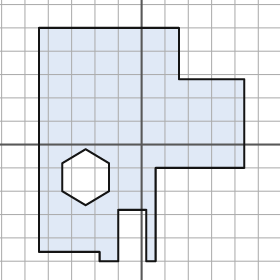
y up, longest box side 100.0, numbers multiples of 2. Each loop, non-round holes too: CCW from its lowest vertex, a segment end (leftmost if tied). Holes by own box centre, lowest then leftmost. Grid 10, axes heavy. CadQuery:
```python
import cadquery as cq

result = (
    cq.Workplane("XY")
    .moveTo(-18.0, -50.0)
    .lineTo(-10.0, -50.0)
    .lineTo(-10.0, -28.0)
    .lineTo(2.0, -28.0)
    .lineTo(2.0, -50.0)
    .lineTo(6.0, -50.0)
    .lineTo(6.0, -10.0)
    .lineTo(44.0, -10.0)
    .lineTo(44.0, 28.0)
    .lineTo(16.0, 28.0)
    .lineTo(16.0, 50.0)
    .lineTo(-44.0, 50.0)
    .lineTo(-44.0, -46.0)
    .lineTo(-18.0, -46.0)
    .close()
    .moveTo(-24.0, -26.0)
    .lineTo(-14.0, -20.0)
    .lineTo(-14.0, -8.0)
    .lineTo(-24.0, -2.0)
    .lineTo(-34.0, -8.0)
    .lineTo(-34.0, -20.0)
    .close()
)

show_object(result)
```